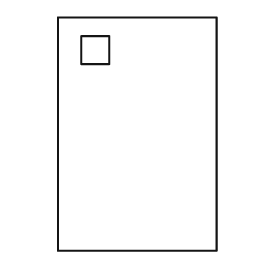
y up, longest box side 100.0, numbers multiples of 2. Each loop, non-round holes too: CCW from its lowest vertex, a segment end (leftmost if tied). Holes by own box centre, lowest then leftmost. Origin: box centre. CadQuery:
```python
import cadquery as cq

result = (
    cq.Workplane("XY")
    .moveTo(-34.0, -50.0)
    .lineTo(34.0, -50.0)
    .lineTo(34.0, 50.0)
    .lineTo(-34.0, 50.0)
    .close()
    .moveTo(-24.0, 30.0)
    .lineTo(-12.0, 30.0)
    .lineTo(-12.0, 42.0)
    .lineTo(-24.0, 42.0)
    .close()
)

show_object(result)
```